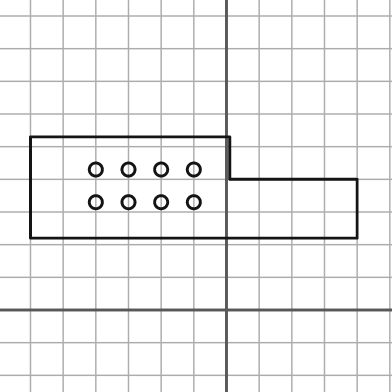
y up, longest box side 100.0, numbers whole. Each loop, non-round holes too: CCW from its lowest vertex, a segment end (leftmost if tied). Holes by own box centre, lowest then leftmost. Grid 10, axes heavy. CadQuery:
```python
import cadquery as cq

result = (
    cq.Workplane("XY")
    .moveTo(-60.0, 22.0)
    .lineTo(40.0, 22.0)
    .lineTo(40.0, 40.0)
    .lineTo(1.0, 40.0)
    .lineTo(1.0, 53.0)
    .lineTo(-60.0, 53.0)
    .close()
    .moveTo(-40.0, 33.0)
    .circle(2.0)
    .moveTo(-30.0, 33.0)
    .circle(2.0)
    .moveTo(-20.0, 33.0)
    .circle(2.0)
    .moveTo(-10.0, 33.0)
    .circle(2.0)
    .moveTo(-40.0, 43.0)
    .circle(2.0)
    .moveTo(-30.0, 43.0)
    .circle(2.0)
    .moveTo(-20.0, 43.0)
    .circle(2.0)
    .moveTo(-10.0, 43.0)
    .circle(2.0)
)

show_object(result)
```